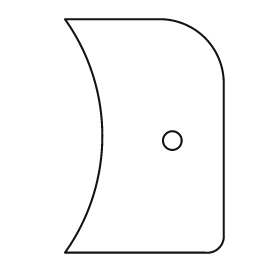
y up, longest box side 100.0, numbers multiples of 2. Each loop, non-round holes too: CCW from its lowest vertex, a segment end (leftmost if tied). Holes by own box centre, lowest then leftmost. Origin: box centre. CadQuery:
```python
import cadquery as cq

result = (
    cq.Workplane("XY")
    .moveTo(-34.0, -50.0)
    .lineTo(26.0, -50.0)
    .threePointArc((32.0, -48.0), (34.0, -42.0))
    .lineTo(34.0, 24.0)
    .threePointArc((26.0, 42.0), (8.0, 50.0))
    .lineTo(-34.0, 50.0)
    .threePointArc((-18.0, 0.0), (-34.0, -50.0))
    .close()
    .moveTo(12.0, -2.0)
    .circle(4.0)
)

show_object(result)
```